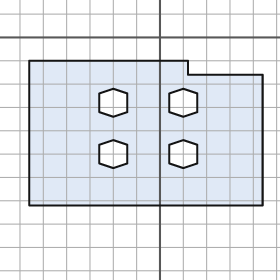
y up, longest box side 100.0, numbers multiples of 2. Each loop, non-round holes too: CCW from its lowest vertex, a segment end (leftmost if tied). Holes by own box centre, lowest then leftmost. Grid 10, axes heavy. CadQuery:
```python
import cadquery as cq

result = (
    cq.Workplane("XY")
    .moveTo(-56.0, -72.0)
    .lineTo(44.0, -72.0)
    .lineTo(44.0, -16.0)
    .lineTo(12.0, -16.0)
    .lineTo(12.0, -10.0)
    .lineTo(-56.0, -10.0)
    .close()
    .moveTo(-20.0, -56.0)
    .lineTo(-14.0, -54.0)
    .lineTo(-14.0, -46.0)
    .lineTo(-20.0, -44.0)
    .lineTo(-26.0, -46.0)
    .lineTo(-26.0, -54.0)
    .close()
    .moveTo(10.0, -56.0)
    .lineTo(16.0, -54.0)
    .lineTo(16.0, -46.0)
    .lineTo(10.0, -44.0)
    .lineTo(4.0, -46.0)
    .lineTo(4.0, -54.0)
    .close()
    .moveTo(-20.0, -34.0)
    .lineTo(-14.0, -32.0)
    .lineTo(-14.0, -24.0)
    .lineTo(-20.0, -22.0)
    .lineTo(-26.0, -24.0)
    .lineTo(-26.0, -32.0)
    .close()
    .moveTo(10.0, -34.0)
    .lineTo(16.0, -32.0)
    .lineTo(16.0, -24.0)
    .lineTo(10.0, -22.0)
    .lineTo(4.0, -24.0)
    .lineTo(4.0, -32.0)
    .close()
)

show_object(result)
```